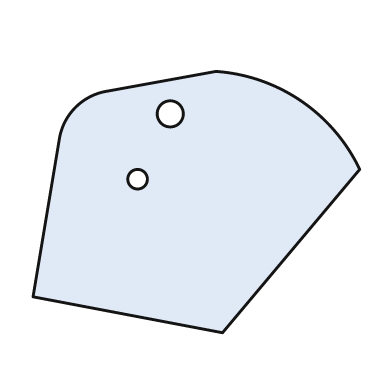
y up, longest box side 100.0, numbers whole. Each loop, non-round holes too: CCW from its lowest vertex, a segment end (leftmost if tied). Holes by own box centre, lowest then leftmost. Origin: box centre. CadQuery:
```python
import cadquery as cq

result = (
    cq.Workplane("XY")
    .moveTo(8.0, -40.0)
    .lineTo(50.0, 10.0)
    .threePointArc((32.0, 31.0), (6.0, 40.0))
    .lineTo(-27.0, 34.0)
    .threePointArc((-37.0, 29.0), (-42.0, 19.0))
    .lineTo(-50.0, -29.0)
    .close()
    .moveTo(-18.0, 7.0)
    .circle(3.0)
    .moveTo(-8.0, 27.0)
    .circle(4.0)
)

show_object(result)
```